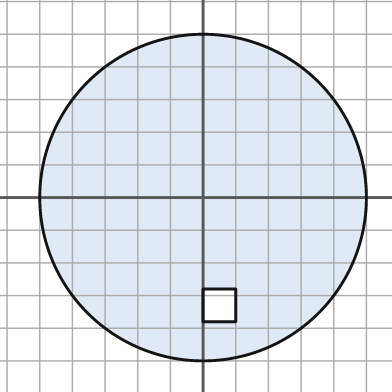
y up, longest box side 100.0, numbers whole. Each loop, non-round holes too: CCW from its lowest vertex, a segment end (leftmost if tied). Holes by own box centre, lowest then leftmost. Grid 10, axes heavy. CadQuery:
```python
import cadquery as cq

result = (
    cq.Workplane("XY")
    .moveTo(0.0, 0.0)
    .circle(50.0)
    .moveTo(0.0, -38.0)
    .lineTo(10.0, -38.0)
    .lineTo(10.0, -28.0)
    .lineTo(0.0, -28.0)
    .close()
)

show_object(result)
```